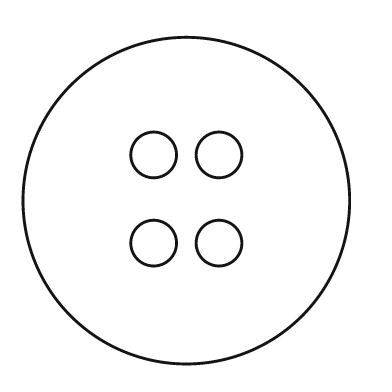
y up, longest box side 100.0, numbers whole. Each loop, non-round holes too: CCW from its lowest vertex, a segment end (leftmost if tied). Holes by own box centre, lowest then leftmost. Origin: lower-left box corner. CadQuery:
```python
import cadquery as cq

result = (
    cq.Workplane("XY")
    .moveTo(50.0, 50.0)
    .circle(50.0)
    .moveTo(40.0, 37.0)
    .circle(7.0)
    .moveTo(60.0, 37.0)
    .circle(7.0)
    .moveTo(40.0, 64.0)
    .circle(7.0)
    .moveTo(60.0, 64.0)
    .circle(7.0)
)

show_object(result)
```